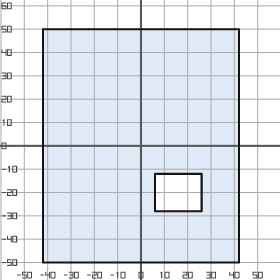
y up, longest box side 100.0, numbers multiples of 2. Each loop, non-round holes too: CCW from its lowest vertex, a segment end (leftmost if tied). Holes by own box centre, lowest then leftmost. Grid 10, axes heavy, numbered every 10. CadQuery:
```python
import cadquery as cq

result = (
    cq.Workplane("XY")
    .moveTo(-42.0, -50.0)
    .lineTo(42.0, -50.0)
    .lineTo(42.0, 50.0)
    .lineTo(-42.0, 50.0)
    .close()
    .moveTo(6.0, -28.0)
    .lineTo(26.0, -28.0)
    .lineTo(26.0, -12.0)
    .lineTo(6.0, -12.0)
    .close()
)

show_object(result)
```